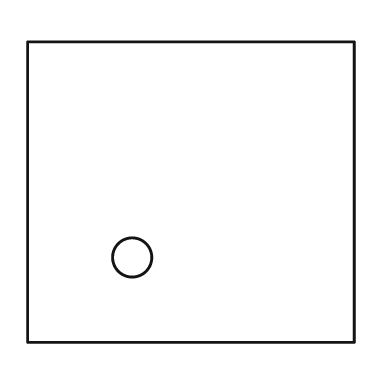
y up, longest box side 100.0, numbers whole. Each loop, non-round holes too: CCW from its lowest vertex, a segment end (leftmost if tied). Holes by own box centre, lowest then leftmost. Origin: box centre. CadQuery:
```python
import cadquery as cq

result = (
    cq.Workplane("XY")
    .moveTo(-50.0, -46.0)
    .lineTo(50.0, -46.0)
    .lineTo(50.0, 46.0)
    .lineTo(-50.0, 46.0)
    .close()
    .moveTo(-18.0, -20.0)
    .circle(6.0)
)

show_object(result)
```